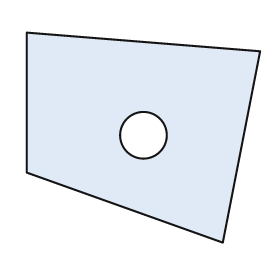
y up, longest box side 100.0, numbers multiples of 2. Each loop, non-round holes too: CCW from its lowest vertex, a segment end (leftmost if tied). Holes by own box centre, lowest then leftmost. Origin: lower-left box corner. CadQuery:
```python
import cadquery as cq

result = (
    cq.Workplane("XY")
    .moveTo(84.0, 0.0)
    .lineTo(100.0, 82.0)
    .lineTo(0.0, 90.0)
    .lineTo(0.0, 30.0)
    .close()
    .moveTo(50.0, 46.0)
    .circle(10.0)
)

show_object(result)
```